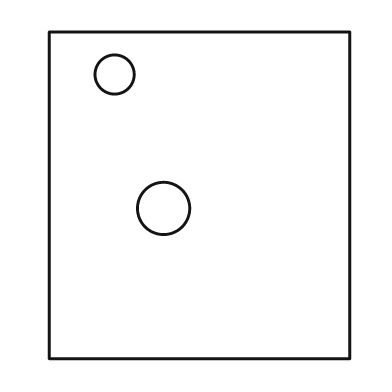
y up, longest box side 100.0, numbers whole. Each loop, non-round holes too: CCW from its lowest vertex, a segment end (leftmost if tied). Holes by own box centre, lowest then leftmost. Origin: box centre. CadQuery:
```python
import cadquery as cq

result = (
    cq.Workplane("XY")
    .moveTo(-46.0, -50.0)
    .lineTo(46.0, -50.0)
    .lineTo(46.0, 50.0)
    .lineTo(-46.0, 50.0)
    .close()
    .moveTo(-11.0, -4.0)
    .circle(8.0)
    .moveTo(-26.0, 37.0)
    .circle(6.0)
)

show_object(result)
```